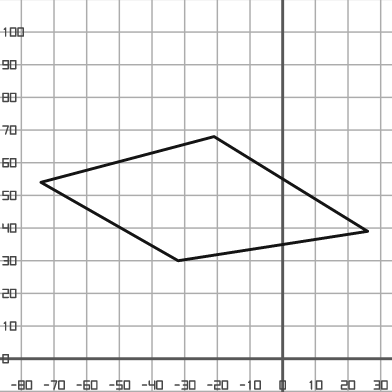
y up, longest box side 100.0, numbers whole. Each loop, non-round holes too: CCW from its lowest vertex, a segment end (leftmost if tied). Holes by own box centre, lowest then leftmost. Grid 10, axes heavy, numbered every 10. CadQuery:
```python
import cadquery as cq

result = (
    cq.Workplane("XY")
    .moveTo(-32.0, 30.0)
    .lineTo(26.0, 39.0)
    .lineTo(-21.0, 68.0)
    .lineTo(-74.0, 54.0)
    .close()
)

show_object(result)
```